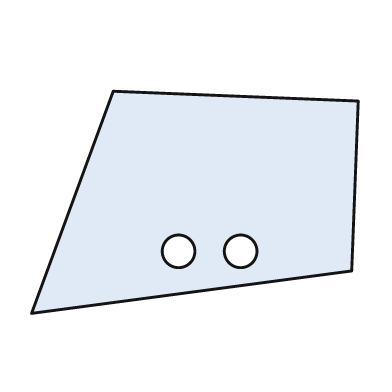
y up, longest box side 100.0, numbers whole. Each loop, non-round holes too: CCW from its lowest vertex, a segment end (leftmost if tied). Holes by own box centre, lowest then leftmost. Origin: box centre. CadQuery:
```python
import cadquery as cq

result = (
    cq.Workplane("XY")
    .moveTo(-50.0, -34.0)
    .lineTo(48.0, -21.0)
    .lineTo(50.0, 31.0)
    .lineTo(-25.0, 34.0)
    .close()
    .moveTo(-5.0, -15.0)
    .circle(5.0)
    .moveTo(14.0, -15.0)
    .circle(5.0)
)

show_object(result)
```